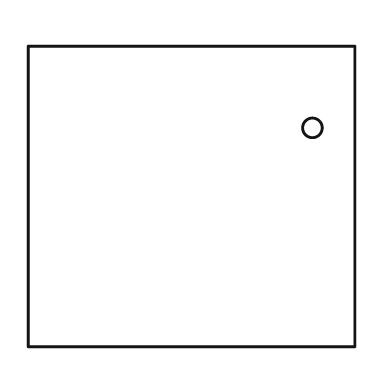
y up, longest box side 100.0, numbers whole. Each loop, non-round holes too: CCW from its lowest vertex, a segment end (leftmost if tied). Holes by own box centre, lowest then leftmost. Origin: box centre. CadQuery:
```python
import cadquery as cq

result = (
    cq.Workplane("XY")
    .moveTo(-50.0, -46.0)
    .lineTo(50.0, -46.0)
    .lineTo(50.0, 46.0)
    .lineTo(-50.0, 46.0)
    .close()
    .moveTo(37.0, 21.0)
    .circle(3.0)
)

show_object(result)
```